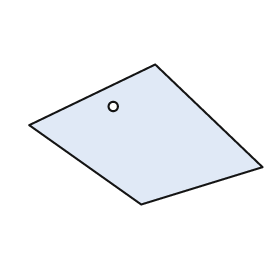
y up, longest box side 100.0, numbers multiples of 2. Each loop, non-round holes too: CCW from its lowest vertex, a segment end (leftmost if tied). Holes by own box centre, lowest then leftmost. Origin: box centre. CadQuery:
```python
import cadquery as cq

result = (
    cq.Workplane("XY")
    .moveTo(-2.0, -30.0)
    .lineTo(50.0, -14.0)
    .lineTo(4.0, 30.0)
    .lineTo(-50.0, 4.0)
    .close()
    .moveTo(-14.0, 12.0)
    .circle(2.0)
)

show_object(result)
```